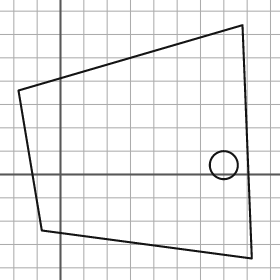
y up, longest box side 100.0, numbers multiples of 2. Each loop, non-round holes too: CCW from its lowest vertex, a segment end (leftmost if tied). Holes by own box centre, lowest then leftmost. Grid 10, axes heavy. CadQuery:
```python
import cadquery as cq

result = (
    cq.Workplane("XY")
    .moveTo(82.0, -36.0)
    .lineTo(78.0, 64.0)
    .lineTo(-18.0, 36.0)
    .lineTo(-8.0, -24.0)
    .close()
    .moveTo(70.0, 4.0)
    .circle(6.0)
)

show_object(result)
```